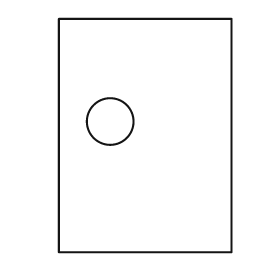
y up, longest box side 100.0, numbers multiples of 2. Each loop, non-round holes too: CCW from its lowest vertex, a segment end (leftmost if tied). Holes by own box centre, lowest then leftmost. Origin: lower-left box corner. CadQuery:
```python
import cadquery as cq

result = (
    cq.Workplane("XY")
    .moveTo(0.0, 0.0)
    .lineTo(74.0, 0.0)
    .lineTo(74.0, 100.0)
    .lineTo(0.0, 100.0)
    .close()
    .moveTo(22.0, 56.0)
    .circle(10.0)
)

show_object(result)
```